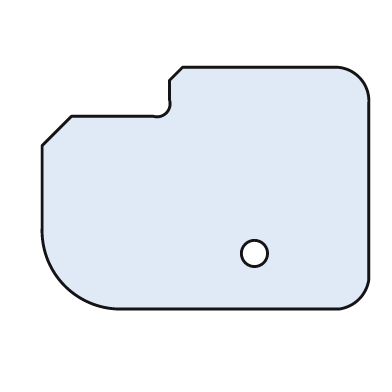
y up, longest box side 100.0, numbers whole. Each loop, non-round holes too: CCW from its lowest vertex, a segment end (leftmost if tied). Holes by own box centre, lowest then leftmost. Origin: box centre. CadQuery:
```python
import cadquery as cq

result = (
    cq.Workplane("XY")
    .moveTo(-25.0, -37.0)
    .lineTo(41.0, -37.0)
    .threePointArc((47.0, -34.0), (50.0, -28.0))
    .lineTo(50.0, 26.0)
    .threePointArc((47.0, 34.0), (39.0, 37.0))
    .lineTo(-7.0, 37.0)
    .lineTo(-11.0, 33.0)
    .lineTo(-11.0, 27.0)
    .threePointArc((-12.0, 23.0), (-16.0, 22.0))
    .lineTo(-41.0, 22.0)
    .lineTo(-50.0, 13.0)
    .lineTo(-50.0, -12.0)
    .threePointArc((-43.0, -30.0), (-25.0, -37.0))
    .close()
    .moveTo(15.0, -20.0)
    .circle(4.0)
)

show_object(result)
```